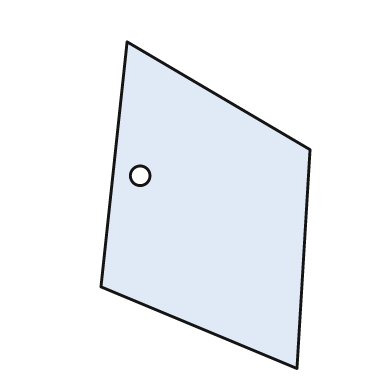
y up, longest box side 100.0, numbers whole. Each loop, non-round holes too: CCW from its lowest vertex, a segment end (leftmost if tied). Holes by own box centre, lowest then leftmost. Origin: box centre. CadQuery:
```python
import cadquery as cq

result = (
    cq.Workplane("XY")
    .moveTo(28.0, -50.0)
    .lineTo(32.0, 17.0)
    .lineTo(-24.0, 50.0)
    .lineTo(-32.0, -25.0)
    .close()
    .moveTo(-20.0, 9.0)
    .circle(3.0)
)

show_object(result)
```